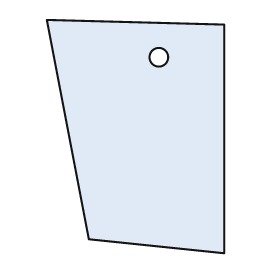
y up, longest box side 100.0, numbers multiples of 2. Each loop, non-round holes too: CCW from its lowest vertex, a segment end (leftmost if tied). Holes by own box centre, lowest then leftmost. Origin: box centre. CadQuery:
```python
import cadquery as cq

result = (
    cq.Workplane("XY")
    .moveTo(38.0, -50.0)
    .lineTo(38.0, 48.0)
    .lineTo(-38.0, 50.0)
    .lineTo(-20.0, -44.0)
    .close()
    .moveTo(10.0, 34.0)
    .circle(4.0)
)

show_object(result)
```